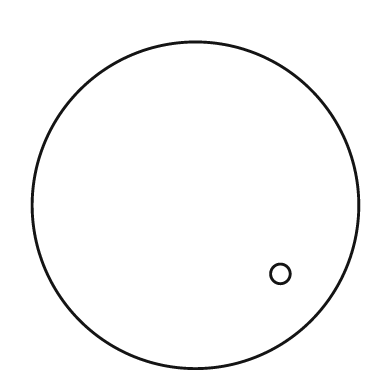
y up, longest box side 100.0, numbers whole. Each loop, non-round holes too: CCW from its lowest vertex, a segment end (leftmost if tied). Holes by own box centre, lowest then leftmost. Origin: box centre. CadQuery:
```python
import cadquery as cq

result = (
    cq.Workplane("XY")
    .moveTo(0.0, 0.0)
    .circle(50.0)
    .moveTo(26.0, -21.0)
    .circle(3.0)
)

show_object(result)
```